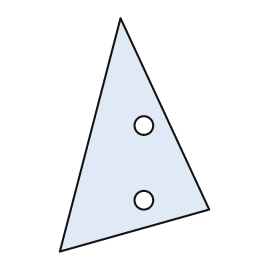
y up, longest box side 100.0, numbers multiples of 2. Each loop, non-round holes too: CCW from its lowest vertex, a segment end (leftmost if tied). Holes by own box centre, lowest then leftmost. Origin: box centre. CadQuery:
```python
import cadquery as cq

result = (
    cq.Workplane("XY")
    .moveTo(-32.0, -50.0)
    .lineTo(32.0, -32.0)
    .lineTo(-6.0, 50.0)
    .close()
    .moveTo(4.0, -28.0)
    .circle(4.0)
    .moveTo(4.0, 4.0)
    .circle(4.0)
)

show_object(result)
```